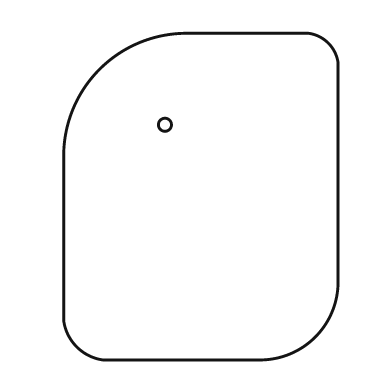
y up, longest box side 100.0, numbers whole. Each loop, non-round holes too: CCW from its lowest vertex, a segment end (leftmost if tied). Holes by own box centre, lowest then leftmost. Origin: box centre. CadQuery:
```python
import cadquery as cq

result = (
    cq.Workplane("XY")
    .moveTo(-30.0, -50.0)
    .lineTo(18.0, -50.0)
    .threePointArc((35.0, -43.0), (42.0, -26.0))
    .lineTo(42.0, 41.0)
    .threePointArc((39.0, 47.0), (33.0, 50.0))
    .lineTo(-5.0, 50.0)
    .threePointArc((-31.0, 39.0), (-42.0, 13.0))
    .lineTo(-42.0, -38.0)
    .threePointArc((-38.0, -46.0), (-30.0, -50.0))
    .close()
    .moveTo(-11.0, 22.0)
    .circle(2.0)
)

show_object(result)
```